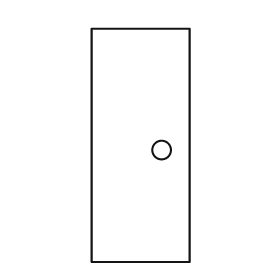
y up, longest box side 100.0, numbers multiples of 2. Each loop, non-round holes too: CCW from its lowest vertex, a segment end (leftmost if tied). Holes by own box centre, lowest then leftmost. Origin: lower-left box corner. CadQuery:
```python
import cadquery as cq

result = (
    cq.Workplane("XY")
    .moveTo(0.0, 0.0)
    .lineTo(42.0, 0.0)
    .lineTo(42.0, 100.0)
    .lineTo(0.0, 100.0)
    .close()
    .moveTo(30.0, 48.0)
    .circle(4.0)
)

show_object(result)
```